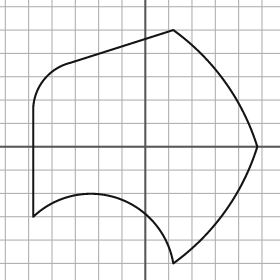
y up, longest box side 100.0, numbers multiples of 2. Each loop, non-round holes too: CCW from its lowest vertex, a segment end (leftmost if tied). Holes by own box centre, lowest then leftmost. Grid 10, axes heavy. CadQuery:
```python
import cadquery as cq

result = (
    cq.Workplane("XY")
    .moveTo(12.0, -50.0)
    .threePointArc((34.0, -28.0), (48.0, 0.0))
    .threePointArc((34.0, 28.0), (12.0, 50.0))
    .lineTo(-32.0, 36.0)
    .threePointArc((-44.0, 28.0), (-48.0, 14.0))
    .lineTo(-48.0, -30.0)
    .threePointArc((-12.0, -22.0), (12.0, -50.0))
    .close()
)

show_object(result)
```